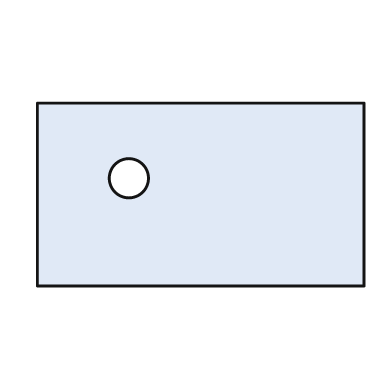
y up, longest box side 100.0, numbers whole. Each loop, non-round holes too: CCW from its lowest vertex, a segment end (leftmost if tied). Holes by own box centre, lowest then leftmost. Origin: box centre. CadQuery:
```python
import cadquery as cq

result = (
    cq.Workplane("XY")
    .moveTo(-50.0, -28.0)
    .lineTo(50.0, -28.0)
    .lineTo(50.0, 28.0)
    .lineTo(-50.0, 28.0)
    .close()
    .moveTo(-22.0, 5.0)
    .circle(6.0)
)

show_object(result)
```